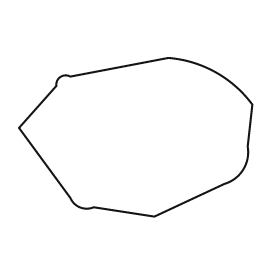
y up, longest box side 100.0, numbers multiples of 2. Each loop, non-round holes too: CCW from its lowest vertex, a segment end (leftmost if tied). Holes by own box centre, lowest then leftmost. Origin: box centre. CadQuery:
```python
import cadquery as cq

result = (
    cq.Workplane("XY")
    .moveTo(8.0, -34.0)
    .lineTo(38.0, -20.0)
    .threePointArc((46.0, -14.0), (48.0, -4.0))
    .lineTo(50.0, 14.0)
    .threePointArc((34.0, 28.0), (14.0, 34.0))
    .lineTo(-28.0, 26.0)
    .threePointArc((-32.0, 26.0), (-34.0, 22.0))
    .lineTo(-50.0, 4.0)
    .lineTo(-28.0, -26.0)
    .threePointArc((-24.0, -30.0), (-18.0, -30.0))
    .close()
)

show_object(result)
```